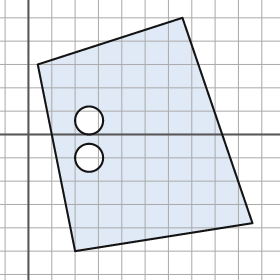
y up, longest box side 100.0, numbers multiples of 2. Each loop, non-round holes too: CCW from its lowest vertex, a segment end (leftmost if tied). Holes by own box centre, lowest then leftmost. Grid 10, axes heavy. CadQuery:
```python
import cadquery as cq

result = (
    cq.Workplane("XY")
    .moveTo(20.0, -50.0)
    .lineTo(96.0, -38.0)
    .lineTo(66.0, 50.0)
    .lineTo(4.0, 30.0)
    .close()
    .moveTo(26.0, -10.0)
    .circle(6.0)
    .moveTo(26.0, 6.0)
    .circle(6.0)
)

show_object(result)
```